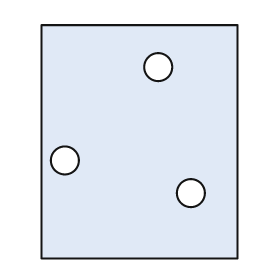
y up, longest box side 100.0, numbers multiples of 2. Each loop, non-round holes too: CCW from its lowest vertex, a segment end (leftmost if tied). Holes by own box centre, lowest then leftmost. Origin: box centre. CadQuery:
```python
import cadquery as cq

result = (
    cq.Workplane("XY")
    .moveTo(-42.0, -50.0)
    .lineTo(42.0, -50.0)
    .lineTo(42.0, 50.0)
    .lineTo(-42.0, 50.0)
    .close()
    .moveTo(22.0, -22.0)
    .circle(6.0)
    .moveTo(-32.0, -8.0)
    .circle(6.0)
    .moveTo(8.0, 32.0)
    .circle(6.0)
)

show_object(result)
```